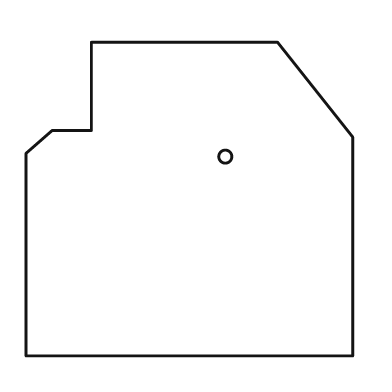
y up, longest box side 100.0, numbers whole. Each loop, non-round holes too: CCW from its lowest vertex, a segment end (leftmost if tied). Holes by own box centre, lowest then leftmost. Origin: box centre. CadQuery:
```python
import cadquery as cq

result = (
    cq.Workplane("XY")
    .moveTo(-50.0, -48.0)
    .lineTo(50.0, -48.0)
    .lineTo(50.0, 19.0)
    .lineTo(27.0, 48.0)
    .lineTo(-30.0, 48.0)
    .lineTo(-30.0, 21.0)
    .lineTo(-42.0, 21.0)
    .lineTo(-50.0, 14.0)
    .close()
    .moveTo(11.0, 13.0)
    .circle(2.0)
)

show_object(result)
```